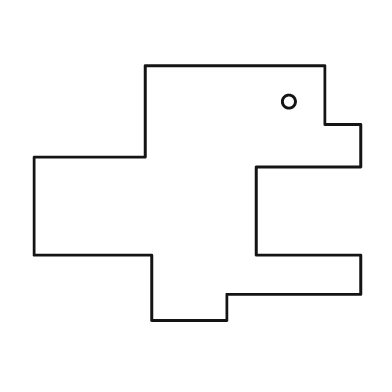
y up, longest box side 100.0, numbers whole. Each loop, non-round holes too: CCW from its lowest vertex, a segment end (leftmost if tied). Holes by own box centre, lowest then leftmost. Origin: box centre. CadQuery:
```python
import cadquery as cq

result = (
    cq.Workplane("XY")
    .moveTo(-14.0, -39.0)
    .lineTo(9.0, -39.0)
    .lineTo(9.0, -31.0)
    .lineTo(50.0, -31.0)
    .lineTo(50.0, -19.0)
    .lineTo(18.0, -19.0)
    .lineTo(18.0, 8.0)
    .lineTo(50.0, 8.0)
    .lineTo(50.0, 21.0)
    .lineTo(39.0, 21.0)
    .lineTo(39.0, 39.0)
    .lineTo(-16.0, 39.0)
    .lineTo(-16.0, 11.0)
    .lineTo(-50.0, 11.0)
    .lineTo(-50.0, -19.0)
    .lineTo(-14.0, -19.0)
    .close()
    .moveTo(28.0, 28.0)
    .circle(2.0)
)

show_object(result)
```